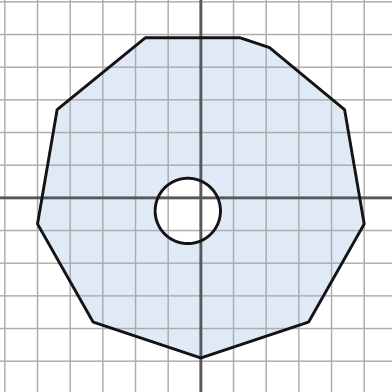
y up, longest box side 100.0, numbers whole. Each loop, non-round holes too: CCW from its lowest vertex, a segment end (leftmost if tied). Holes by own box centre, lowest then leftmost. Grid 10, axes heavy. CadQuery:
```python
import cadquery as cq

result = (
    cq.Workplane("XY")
    .moveTo(0.0, -49.0)
    .lineTo(33.0, -38.0)
    .lineTo(50.0, -8.0)
    .lineTo(44.0, 27.0)
    .lineTo(21.0, 46.0)
    .lineTo(12.0, 49.0)
    .lineTo(-17.0, 49.0)
    .lineTo(-44.0, 27.0)
    .lineTo(-50.0, -8.0)
    .lineTo(-33.0, -38.0)
    .close()
    .moveTo(-4.0, -4.0)
    .circle(10.0)
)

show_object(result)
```